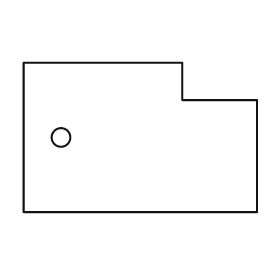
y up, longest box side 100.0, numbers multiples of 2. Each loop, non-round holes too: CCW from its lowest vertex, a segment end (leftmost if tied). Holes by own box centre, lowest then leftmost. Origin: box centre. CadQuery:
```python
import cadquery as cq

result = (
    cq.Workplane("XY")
    .moveTo(-50.0, -32.0)
    .lineTo(50.0, -32.0)
    .lineTo(50.0, 16.0)
    .lineTo(18.0, 16.0)
    .lineTo(18.0, 32.0)
    .lineTo(-50.0, 32.0)
    .close()
    .moveTo(-34.0, 0.0)
    .circle(4.0)
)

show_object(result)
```